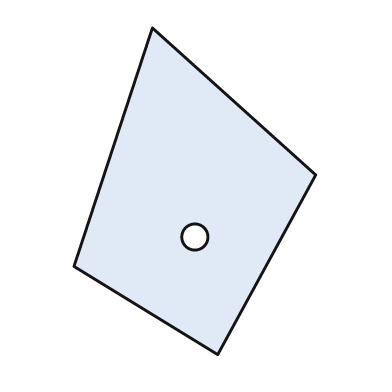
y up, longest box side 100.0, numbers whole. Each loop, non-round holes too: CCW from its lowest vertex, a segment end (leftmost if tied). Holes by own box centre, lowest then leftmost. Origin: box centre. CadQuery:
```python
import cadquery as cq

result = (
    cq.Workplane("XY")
    .moveTo(7.0, -50.0)
    .lineTo(37.0, 5.0)
    .lineTo(-13.0, 50.0)
    .lineTo(-37.0, -23.0)
    .close()
    .moveTo(0.0, -14.0)
    .circle(4.0)
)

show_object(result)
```